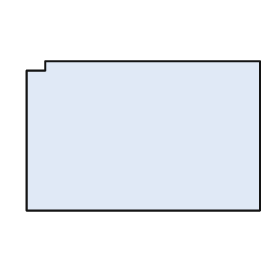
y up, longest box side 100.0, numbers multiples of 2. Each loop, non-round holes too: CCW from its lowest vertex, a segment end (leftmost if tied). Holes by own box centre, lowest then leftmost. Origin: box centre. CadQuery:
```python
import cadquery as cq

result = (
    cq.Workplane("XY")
    .moveTo(-50.0, -32.0)
    .lineTo(50.0, -32.0)
    .lineTo(50.0, 32.0)
    .lineTo(-42.0, 32.0)
    .lineTo(-42.0, 28.0)
    .lineTo(-50.0, 28.0)
    .close()
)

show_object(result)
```